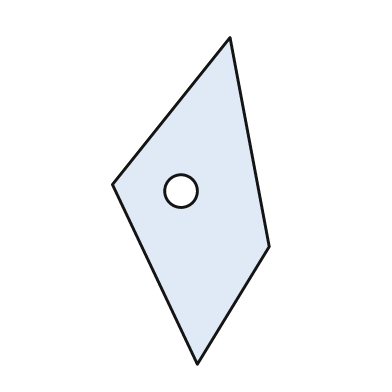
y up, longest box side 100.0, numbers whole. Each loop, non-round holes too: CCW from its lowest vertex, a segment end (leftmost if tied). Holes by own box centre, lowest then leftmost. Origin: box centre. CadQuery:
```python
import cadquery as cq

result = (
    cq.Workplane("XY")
    .moveTo(2.0, -50.0)
    .lineTo(24.0, -14.0)
    .lineTo(12.0, 50.0)
    .lineTo(-24.0, 5.0)
    .close()
    .moveTo(-3.0, 3.0)
    .circle(5.0)
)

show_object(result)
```